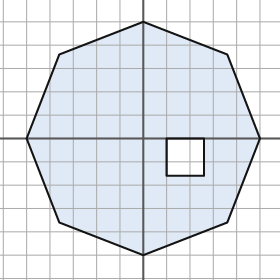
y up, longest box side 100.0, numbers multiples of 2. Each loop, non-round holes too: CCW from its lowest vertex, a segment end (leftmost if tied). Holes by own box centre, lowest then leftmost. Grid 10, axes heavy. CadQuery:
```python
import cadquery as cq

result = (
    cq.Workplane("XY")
    .moveTo(0.0, -50.0)
    .lineTo(36.0, -36.0)
    .lineTo(50.0, 0.0)
    .lineTo(36.0, 36.0)
    .lineTo(0.0, 50.0)
    .lineTo(-36.0, 36.0)
    .lineTo(-50.0, 0.0)
    .lineTo(-36.0, -36.0)
    .close()
    .moveTo(10.0, -16.0)
    .lineTo(26.0, -16.0)
    .lineTo(26.0, 0.0)
    .lineTo(10.0, 0.0)
    .close()
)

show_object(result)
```